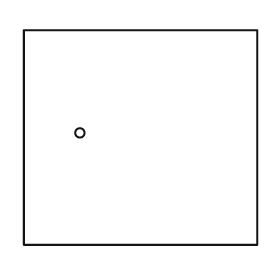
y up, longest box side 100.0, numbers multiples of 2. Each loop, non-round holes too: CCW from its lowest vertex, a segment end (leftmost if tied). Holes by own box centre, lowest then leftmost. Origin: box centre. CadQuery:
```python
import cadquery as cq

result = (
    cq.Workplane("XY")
    .moveTo(-50.0, -46.0)
    .lineTo(50.0, -46.0)
    .lineTo(50.0, 46.0)
    .lineTo(-50.0, 46.0)
    .close()
    .moveTo(-26.0, 2.0)
    .circle(2.0)
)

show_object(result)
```